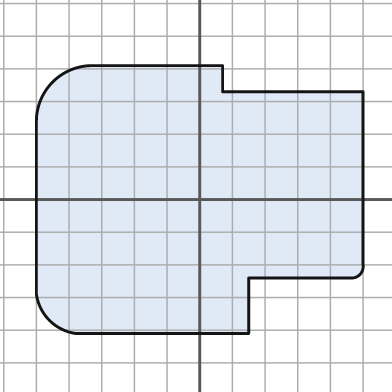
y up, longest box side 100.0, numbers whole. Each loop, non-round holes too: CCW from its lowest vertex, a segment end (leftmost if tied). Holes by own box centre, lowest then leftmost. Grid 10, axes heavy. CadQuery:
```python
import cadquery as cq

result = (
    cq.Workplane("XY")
    .moveTo(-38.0, -41.0)
    .lineTo(15.0, -41.0)
    .lineTo(15.0, -24.0)
    .lineTo(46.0, -24.0)
    .threePointArc((49.0, -23.0), (50.0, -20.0))
    .lineTo(50.0, 33.0)
    .lineTo(7.0, 33.0)
    .lineTo(7.0, 41.0)
    .lineTo(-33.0, 41.0)
    .threePointArc((-45.0, 36.0), (-50.0, 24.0))
    .lineTo(-50.0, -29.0)
    .threePointArc((-46.0, -37.0), (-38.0, -41.0))
    .close()
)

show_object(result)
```